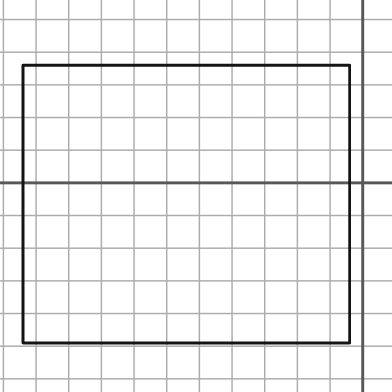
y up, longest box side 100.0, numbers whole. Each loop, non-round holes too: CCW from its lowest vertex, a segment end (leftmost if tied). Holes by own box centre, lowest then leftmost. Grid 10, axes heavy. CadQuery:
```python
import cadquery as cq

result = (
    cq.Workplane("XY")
    .moveTo(-104.0, -49.0)
    .lineTo(-4.0, -49.0)
    .lineTo(-4.0, 36.0)
    .lineTo(-104.0, 36.0)
    .close()
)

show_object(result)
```